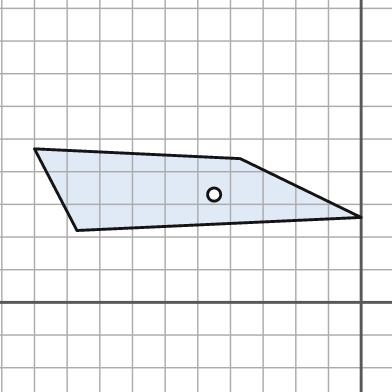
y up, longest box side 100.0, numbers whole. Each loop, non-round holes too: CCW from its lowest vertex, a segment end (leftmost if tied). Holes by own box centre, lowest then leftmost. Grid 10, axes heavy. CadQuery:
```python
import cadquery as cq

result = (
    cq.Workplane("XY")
    .moveTo(-87.0, 22.0)
    .lineTo(0.0, 26.0)
    .lineTo(-37.0, 44.0)
    .lineTo(-100.0, 47.0)
    .close()
    .moveTo(-45.0, 33.0)
    .circle(2.0)
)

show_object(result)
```